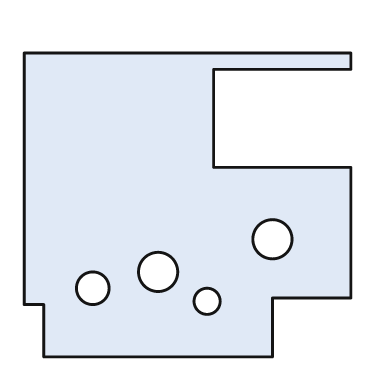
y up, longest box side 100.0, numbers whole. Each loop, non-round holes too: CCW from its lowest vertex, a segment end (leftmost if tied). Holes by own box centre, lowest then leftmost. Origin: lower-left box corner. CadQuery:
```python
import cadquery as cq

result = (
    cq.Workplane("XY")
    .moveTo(6.0, 0.0)
    .lineTo(76.0, 0.0)
    .lineTo(76.0, 18.0)
    .lineTo(100.0, 18.0)
    .lineTo(100.0, 58.0)
    .lineTo(58.0, 58.0)
    .lineTo(58.0, 88.0)
    .lineTo(100.0, 88.0)
    .lineTo(100.0, 93.0)
    .lineTo(0.0, 93.0)
    .lineTo(0.0, 16.0)
    .lineTo(6.0, 16.0)
    .close()
    .moveTo(56.0, 17.0)
    .circle(4.0)
    .moveTo(21.0, 21.0)
    .circle(5.0)
    .moveTo(41.0, 26.0)
    .circle(6.0)
    .moveTo(76.0, 36.0)
    .circle(6.0)
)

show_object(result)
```